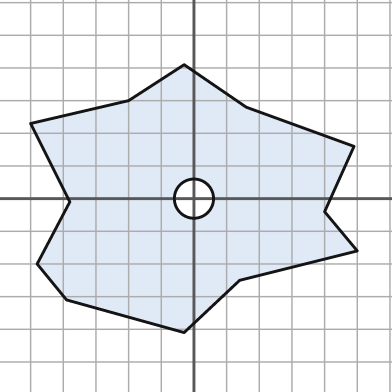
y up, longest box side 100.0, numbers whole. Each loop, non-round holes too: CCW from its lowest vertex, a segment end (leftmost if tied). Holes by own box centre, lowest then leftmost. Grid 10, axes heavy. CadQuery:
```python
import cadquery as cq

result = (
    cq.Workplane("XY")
    .moveTo(-3.0, -41.0)
    .lineTo(14.0, -25.0)
    .lineTo(50.0, -16.0)
    .lineTo(40.0, -4.0)
    .lineTo(49.0, 16.0)
    .lineTo(16.0, 28.0)
    .lineTo(-3.0, 41.0)
    .lineTo(-20.0, 30.0)
    .lineTo(-50.0, 23.0)
    .lineTo(-38.0, -1.0)
    .lineTo(-48.0, -20.0)
    .lineTo(-39.0, -31.0)
    .close()
    .moveTo(0.0, 0.0)
    .circle(6.0)
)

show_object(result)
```